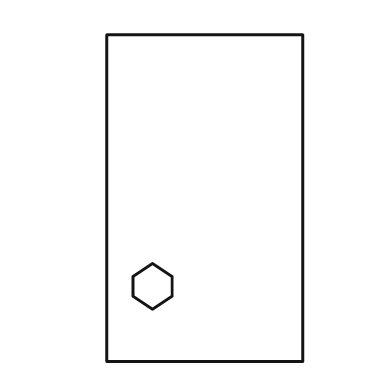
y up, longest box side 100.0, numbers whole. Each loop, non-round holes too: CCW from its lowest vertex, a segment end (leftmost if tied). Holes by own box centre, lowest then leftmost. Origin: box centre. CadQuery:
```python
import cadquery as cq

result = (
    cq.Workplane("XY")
    .moveTo(-30.0, -50.0)
    .lineTo(30.0, -50.0)
    .lineTo(30.0, 50.0)
    .lineTo(-30.0, 50.0)
    .close()
    .moveTo(-16.0, -34.0)
    .lineTo(-10.0, -30.0)
    .lineTo(-10.0, -24.0)
    .lineTo(-16.0, -20.0)
    .lineTo(-22.0, -24.0)
    .lineTo(-22.0, -30.0)
    .close()
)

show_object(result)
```